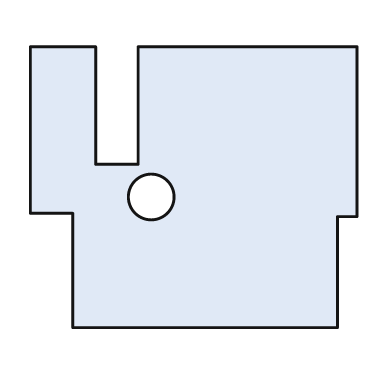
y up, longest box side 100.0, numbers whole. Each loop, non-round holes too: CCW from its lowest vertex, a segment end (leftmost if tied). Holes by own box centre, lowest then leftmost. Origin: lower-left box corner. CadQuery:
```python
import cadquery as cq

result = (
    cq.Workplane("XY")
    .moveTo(13.0, 0.0)
    .lineTo(94.0, 0.0)
    .lineTo(94.0, 34.0)
    .lineTo(100.0, 34.0)
    .lineTo(100.0, 86.0)
    .lineTo(33.0, 86.0)
    .lineTo(33.0, 50.0)
    .lineTo(20.0, 50.0)
    .lineTo(20.0, 86.0)
    .lineTo(0.0, 86.0)
    .lineTo(0.0, 35.0)
    .lineTo(13.0, 35.0)
    .close()
    .moveTo(37.0, 40.0)
    .circle(7.0)
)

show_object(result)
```